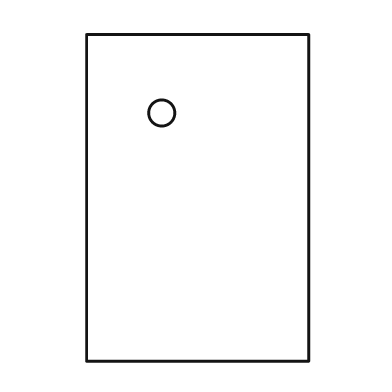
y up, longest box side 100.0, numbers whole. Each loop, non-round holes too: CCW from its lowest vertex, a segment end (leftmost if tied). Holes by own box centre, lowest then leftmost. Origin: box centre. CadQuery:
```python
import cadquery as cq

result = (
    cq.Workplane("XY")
    .moveTo(-34.0, -50.0)
    .lineTo(34.0, -50.0)
    .lineTo(34.0, 50.0)
    .lineTo(-34.0, 50.0)
    .close()
    .moveTo(-11.0, 26.0)
    .circle(4.0)
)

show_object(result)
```